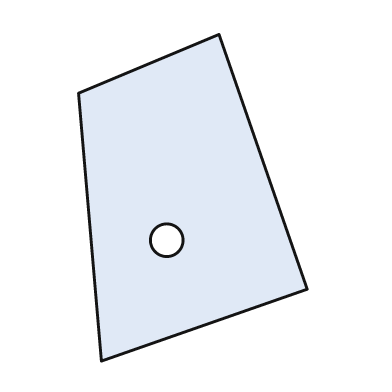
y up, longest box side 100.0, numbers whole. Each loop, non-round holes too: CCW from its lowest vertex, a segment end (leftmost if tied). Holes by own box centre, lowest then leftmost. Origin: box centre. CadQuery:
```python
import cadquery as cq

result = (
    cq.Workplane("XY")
    .moveTo(-28.0, -50.0)
    .lineTo(35.0, -28.0)
    .lineTo(8.0, 50.0)
    .lineTo(-35.0, 32.0)
    .close()
    .moveTo(-8.0, -13.0)
    .circle(5.0)
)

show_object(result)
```